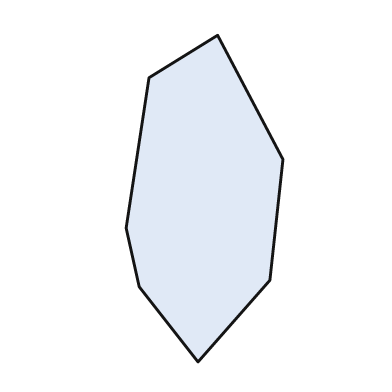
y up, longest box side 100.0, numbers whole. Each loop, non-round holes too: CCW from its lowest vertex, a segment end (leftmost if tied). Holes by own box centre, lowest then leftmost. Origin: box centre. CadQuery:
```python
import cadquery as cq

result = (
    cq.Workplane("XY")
    .moveTo(-2.0, -50.0)
    .lineTo(20.0, -25.0)
    .lineTo(24.0, 12.0)
    .lineTo(4.0, 50.0)
    .lineTo(-17.0, 37.0)
    .lineTo(-24.0, -9.0)
    .lineTo(-20.0, -27.0)
    .close()
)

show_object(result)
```